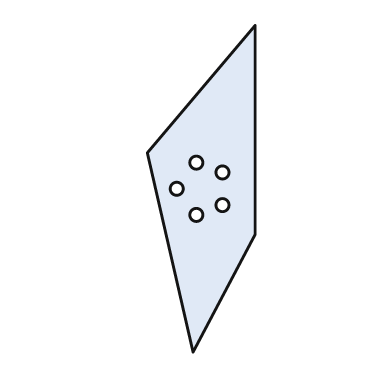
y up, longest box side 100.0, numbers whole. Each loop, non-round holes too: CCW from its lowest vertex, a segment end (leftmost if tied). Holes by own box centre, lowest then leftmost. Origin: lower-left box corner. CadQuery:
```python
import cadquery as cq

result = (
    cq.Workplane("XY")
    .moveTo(14.0, 0.0)
    .lineTo(33.0, 36.0)
    .lineTo(33.0, 100.0)
    .lineTo(0.0, 61.0)
    .close()
    .moveTo(15.0, 42.0)
    .circle(2.0)
    .moveTo(23.0, 45.0)
    .circle(2.0)
    .moveTo(9.0, 50.0)
    .circle(2.0)
    .moveTo(23.0, 55.0)
    .circle(2.0)
    .moveTo(15.0, 58.0)
    .circle(2.0)
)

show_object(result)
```